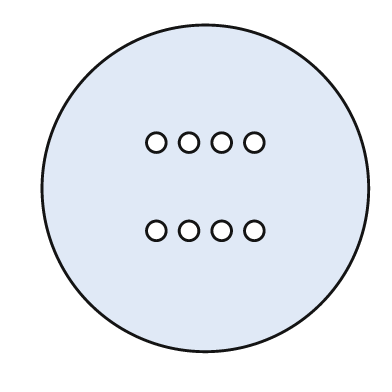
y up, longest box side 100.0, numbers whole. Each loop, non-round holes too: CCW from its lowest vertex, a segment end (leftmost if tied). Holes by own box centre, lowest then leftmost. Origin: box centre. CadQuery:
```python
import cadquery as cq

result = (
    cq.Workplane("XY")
    .moveTo(0.0, 0.0)
    .circle(50.0)
    .moveTo(-15.0, -13.0)
    .circle(3.0)
    .moveTo(-5.0, -13.0)
    .circle(3.0)
    .moveTo(5.0, -13.0)
    .circle(3.0)
    .moveTo(15.0, -13.0)
    .circle(3.0)
    .moveTo(-15.0, 14.0)
    .circle(3.0)
    .moveTo(-5.0, 14.0)
    .circle(3.0)
    .moveTo(5.0, 14.0)
    .circle(3.0)
    .moveTo(15.0, 14.0)
    .circle(3.0)
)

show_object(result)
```